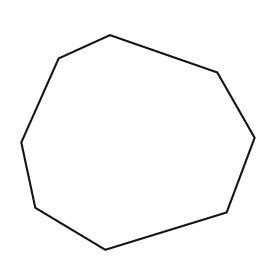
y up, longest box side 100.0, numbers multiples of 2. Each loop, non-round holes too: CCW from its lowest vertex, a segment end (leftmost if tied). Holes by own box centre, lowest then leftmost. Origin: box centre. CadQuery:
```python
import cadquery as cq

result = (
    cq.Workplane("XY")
    .moveTo(-14.0, -46.0)
    .lineTo(38.0, -30.0)
    .lineTo(50.0, 2.0)
    .lineTo(34.0, 30.0)
    .lineTo(-12.0, 46.0)
    .lineTo(-34.0, 36.0)
    .lineTo(-50.0, 0.0)
    .lineTo(-44.0, -28.0)
    .close()
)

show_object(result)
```